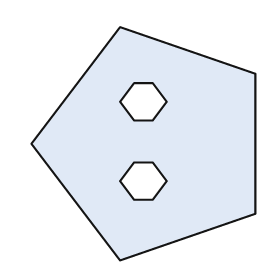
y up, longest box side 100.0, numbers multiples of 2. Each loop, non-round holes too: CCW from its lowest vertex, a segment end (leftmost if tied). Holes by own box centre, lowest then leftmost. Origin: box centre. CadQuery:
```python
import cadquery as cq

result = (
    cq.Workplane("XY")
    .moveTo(-10.0, -50.0)
    .lineTo(48.0, -30.0)
    .lineTo(48.0, 30.0)
    .lineTo(-10.0, 50.0)
    .lineTo(-48.0, 0.0)
    .close()
    .moveTo(-4.0, -24.0)
    .lineTo(4.0, -24.0)
    .lineTo(10.0, -16.0)
    .lineTo(4.0, -8.0)
    .lineTo(-4.0, -8.0)
    .lineTo(-10.0, -16.0)
    .close()
    .moveTo(-4.0, 10.0)
    .lineTo(4.0, 10.0)
    .lineTo(10.0, 18.0)
    .lineTo(4.0, 26.0)
    .lineTo(-4.0, 26.0)
    .lineTo(-10.0, 18.0)
    .close()
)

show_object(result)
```